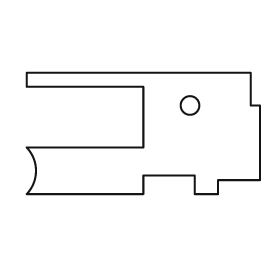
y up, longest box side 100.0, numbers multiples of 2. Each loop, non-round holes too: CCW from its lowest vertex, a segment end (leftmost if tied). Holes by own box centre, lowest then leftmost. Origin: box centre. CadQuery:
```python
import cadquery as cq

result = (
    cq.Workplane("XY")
    .moveTo(-50.0, -26.0)
    .lineTo(0.0, -26.0)
    .lineTo(0.0, -18.0)
    .lineTo(22.0, -18.0)
    .lineTo(22.0, -26.0)
    .lineTo(32.0, -26.0)
    .lineTo(32.0, -20.0)
    .lineTo(50.0, -20.0)
    .lineTo(50.0, 12.0)
    .lineTo(46.0, 12.0)
    .lineTo(46.0, 26.0)
    .lineTo(-50.0, 26.0)
    .lineTo(-50.0, 20.0)
    .lineTo(0.0, 20.0)
    .lineTo(0.0, -6.0)
    .lineTo(-50.0, -6.0)
    .threePointArc((-46.0, -16.0), (-50.0, -26.0))
    .close()
    .moveTo(20.0, 12.0)
    .circle(4.0)
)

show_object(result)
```